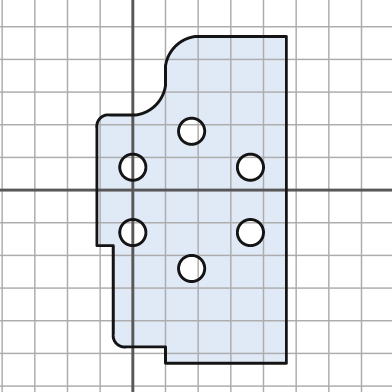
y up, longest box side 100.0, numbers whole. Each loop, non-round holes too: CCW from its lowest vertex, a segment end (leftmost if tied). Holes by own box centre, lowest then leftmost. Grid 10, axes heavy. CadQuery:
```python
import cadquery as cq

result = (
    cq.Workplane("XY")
    .moveTo(10.0, -53.0)
    .lineTo(47.0, -53.0)
    .lineTo(47.0, 47.0)
    .lineTo(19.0, 47.0)
    .threePointArc((13.0, 44.0), (10.0, 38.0))
    .lineTo(10.0, 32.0)
    .threePointArc((7.0, 26.0), (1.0, 23.0))
    .lineTo(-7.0, 23.0)
    .threePointArc((-10.0, 22.0), (-11.0, 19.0))
    .lineTo(-11.0, -17.0)
    .lineTo(-6.0, -17.0)
    .lineTo(-6.0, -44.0)
    .threePointArc((-5.0, -47.0), (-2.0, -48.0))
    .lineTo(10.0, -48.0)
    .close()
    .moveTo(18.0, -24.0)
    .circle(4.0)
    .moveTo(0.0, -13.0)
    .circle(4.0)
    .moveTo(36.0, -13.0)
    .circle(4.0)
    .moveTo(0.0, 7.0)
    .circle(4.0)
    .moveTo(36.0, 7.0)
    .circle(4.0)
    .moveTo(18.0, 18.0)
    .circle(4.0)
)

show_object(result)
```